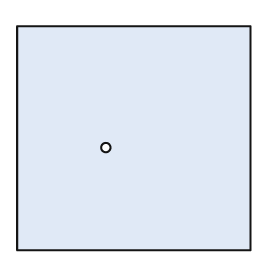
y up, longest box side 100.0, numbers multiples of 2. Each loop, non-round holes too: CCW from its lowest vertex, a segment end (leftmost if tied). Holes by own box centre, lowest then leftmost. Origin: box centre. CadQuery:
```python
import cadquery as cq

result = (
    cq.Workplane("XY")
    .moveTo(-50.0, -48.0)
    .lineTo(50.0, -48.0)
    .lineTo(50.0, 48.0)
    .lineTo(-50.0, 48.0)
    .close()
    .moveTo(-12.0, -4.0)
    .circle(2.0)
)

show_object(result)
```